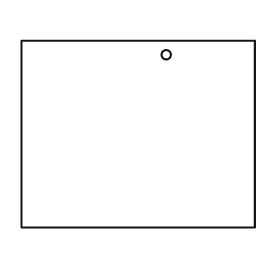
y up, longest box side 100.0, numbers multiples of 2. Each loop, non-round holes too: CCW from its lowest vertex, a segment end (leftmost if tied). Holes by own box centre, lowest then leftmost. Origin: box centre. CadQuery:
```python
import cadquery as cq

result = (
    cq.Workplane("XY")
    .moveTo(-50.0, -40.0)
    .lineTo(50.0, -40.0)
    .lineTo(50.0, 40.0)
    .lineTo(-50.0, 40.0)
    .close()
    .moveTo(12.0, 34.0)
    .circle(2.0)
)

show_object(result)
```